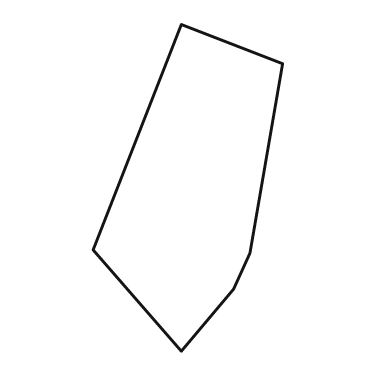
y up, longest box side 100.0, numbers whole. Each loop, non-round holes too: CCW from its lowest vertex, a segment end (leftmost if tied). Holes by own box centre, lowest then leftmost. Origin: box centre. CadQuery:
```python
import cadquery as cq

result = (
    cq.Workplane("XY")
    .moveTo(-2.0, -50.0)
    .lineTo(14.0, -31.0)
    .lineTo(19.0, -20.0)
    .lineTo(29.0, 38.0)
    .lineTo(-2.0, 50.0)
    .lineTo(-29.0, -19.0)
    .close()
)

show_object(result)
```